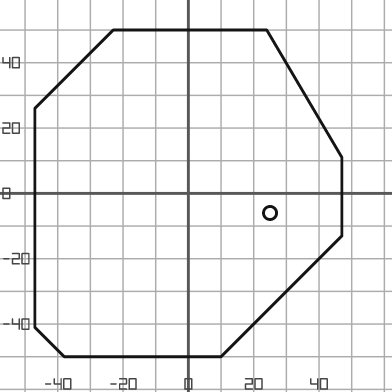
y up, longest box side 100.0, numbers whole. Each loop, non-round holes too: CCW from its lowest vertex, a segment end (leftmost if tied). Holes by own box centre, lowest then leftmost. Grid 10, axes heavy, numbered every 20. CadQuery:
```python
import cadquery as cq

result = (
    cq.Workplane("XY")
    .moveTo(-38.0, -50.0)
    .lineTo(10.0, -50.0)
    .lineTo(47.0, -13.0)
    .lineTo(47.0, 11.0)
    .lineTo(24.0, 50.0)
    .lineTo(-23.0, 50.0)
    .lineTo(-47.0, 26.0)
    .lineTo(-47.0, -41.0)
    .close()
    .moveTo(25.0, -6.0)
    .circle(2.0)
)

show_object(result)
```